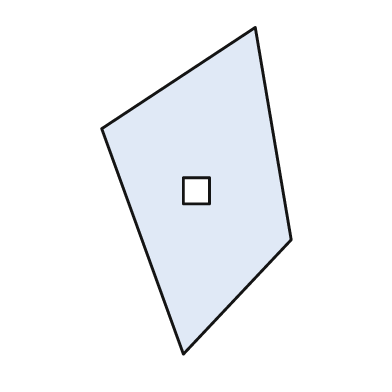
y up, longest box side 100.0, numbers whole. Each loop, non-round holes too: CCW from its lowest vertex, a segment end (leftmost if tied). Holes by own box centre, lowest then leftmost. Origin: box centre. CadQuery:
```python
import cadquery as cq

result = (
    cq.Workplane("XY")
    .moveTo(-4.0, -50.0)
    .lineTo(29.0, -15.0)
    .lineTo(18.0, 50.0)
    .lineTo(-29.0, 19.0)
    .close()
    .moveTo(-4.0, -4.0)
    .lineTo(4.0, -4.0)
    .lineTo(4.0, 4.0)
    .lineTo(-4.0, 4.0)
    .close()
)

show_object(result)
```